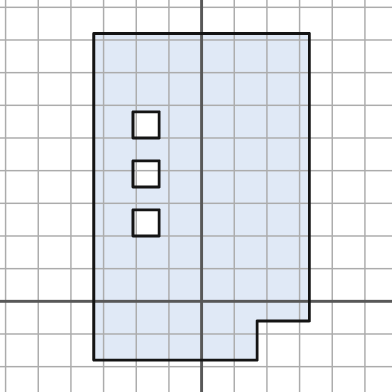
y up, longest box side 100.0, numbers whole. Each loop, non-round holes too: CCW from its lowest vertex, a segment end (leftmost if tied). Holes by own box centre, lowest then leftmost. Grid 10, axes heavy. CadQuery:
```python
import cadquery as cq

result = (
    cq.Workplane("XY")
    .moveTo(-33.0, -18.0)
    .lineTo(17.0, -18.0)
    .lineTo(17.0, -6.0)
    .lineTo(33.0, -6.0)
    .lineTo(33.0, 82.0)
    .lineTo(-33.0, 82.0)
    .close()
    .moveTo(-21.0, 20.0)
    .lineTo(-13.0, 20.0)
    .lineTo(-13.0, 28.0)
    .lineTo(-21.0, 28.0)
    .close()
    .moveTo(-21.0, 35.0)
    .lineTo(-13.0, 35.0)
    .lineTo(-13.0, 43.0)
    .lineTo(-21.0, 43.0)
    .close()
    .moveTo(-21.0, 50.0)
    .lineTo(-13.0, 50.0)
    .lineTo(-13.0, 58.0)
    .lineTo(-21.0, 58.0)
    .close()
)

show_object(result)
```